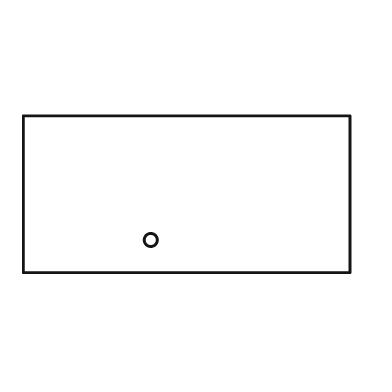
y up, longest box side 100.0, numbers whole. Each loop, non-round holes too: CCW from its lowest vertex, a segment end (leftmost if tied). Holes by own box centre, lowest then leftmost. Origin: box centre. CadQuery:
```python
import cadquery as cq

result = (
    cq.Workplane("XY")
    .moveTo(-50.0, -24.0)
    .lineTo(50.0, -24.0)
    .lineTo(50.0, 24.0)
    .lineTo(-50.0, 24.0)
    .close()
    .moveTo(-11.0, -14.0)
    .circle(2.0)
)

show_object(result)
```